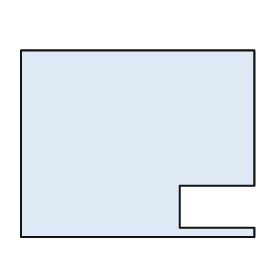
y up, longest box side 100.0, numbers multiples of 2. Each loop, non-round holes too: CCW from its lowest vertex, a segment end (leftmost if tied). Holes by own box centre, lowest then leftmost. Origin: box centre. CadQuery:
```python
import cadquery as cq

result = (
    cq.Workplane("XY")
    .moveTo(-50.0, -40.0)
    .lineTo(50.0, -40.0)
    .lineTo(50.0, -36.0)
    .lineTo(18.0, -36.0)
    .lineTo(18.0, -18.0)
    .lineTo(50.0, -18.0)
    .lineTo(50.0, 40.0)
    .lineTo(-50.0, 40.0)
    .close()
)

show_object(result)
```